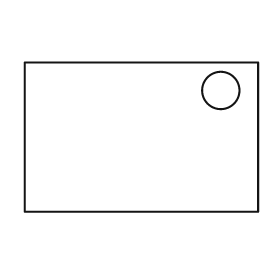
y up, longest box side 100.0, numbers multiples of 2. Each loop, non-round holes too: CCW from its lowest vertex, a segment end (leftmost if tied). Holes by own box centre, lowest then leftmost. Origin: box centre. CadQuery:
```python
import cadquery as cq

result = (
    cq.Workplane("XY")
    .moveTo(-50.0, -32.0)
    .lineTo(50.0, -32.0)
    .lineTo(50.0, 32.0)
    .lineTo(-50.0, 32.0)
    .close()
    .moveTo(34.0, 20.0)
    .circle(8.0)
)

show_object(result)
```